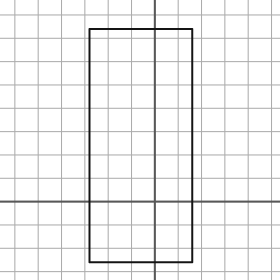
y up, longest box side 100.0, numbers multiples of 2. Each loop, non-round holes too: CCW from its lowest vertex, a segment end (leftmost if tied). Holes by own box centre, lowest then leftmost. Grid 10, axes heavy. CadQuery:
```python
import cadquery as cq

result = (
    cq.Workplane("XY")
    .moveTo(-28.0, -26.0)
    .lineTo(16.0, -26.0)
    .lineTo(16.0, 74.0)
    .lineTo(-28.0, 74.0)
    .close()
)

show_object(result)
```